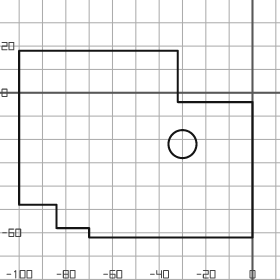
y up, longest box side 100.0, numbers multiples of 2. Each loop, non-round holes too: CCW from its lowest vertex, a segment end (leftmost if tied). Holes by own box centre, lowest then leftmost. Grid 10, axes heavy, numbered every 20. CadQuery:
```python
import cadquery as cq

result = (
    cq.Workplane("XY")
    .moveTo(-70.0, -62.0)
    .lineTo(0.0, -62.0)
    .lineTo(0.0, -4.0)
    .lineTo(-32.0, -4.0)
    .lineTo(-32.0, 18.0)
    .lineTo(-100.0, 18.0)
    .lineTo(-100.0, -48.0)
    .lineTo(-84.0, -48.0)
    .lineTo(-84.0, -58.0)
    .lineTo(-70.0, -58.0)
    .close()
    .moveTo(-30.0, -22.0)
    .circle(6.0)
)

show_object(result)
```